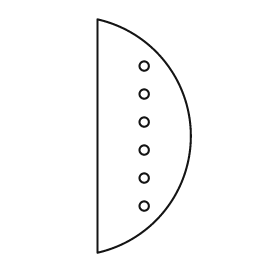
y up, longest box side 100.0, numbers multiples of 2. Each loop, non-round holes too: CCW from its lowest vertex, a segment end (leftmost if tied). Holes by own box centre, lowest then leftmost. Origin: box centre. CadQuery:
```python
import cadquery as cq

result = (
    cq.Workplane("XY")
    .moveTo(-20.0, -50.0)
    .threePointArc((20.0, 0.0), (-20.0, 50.0))
    .close()
    .moveTo(0.0, -30.0)
    .circle(2.0)
    .moveTo(0.0, -18.0)
    .circle(2.0)
    .moveTo(0.0, -6.0)
    .circle(2.0)
    .moveTo(0.0, 6.0)
    .circle(2.0)
    .moveTo(0.0, 18.0)
    .circle(2.0)
    .moveTo(0.0, 30.0)
    .circle(2.0)
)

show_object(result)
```